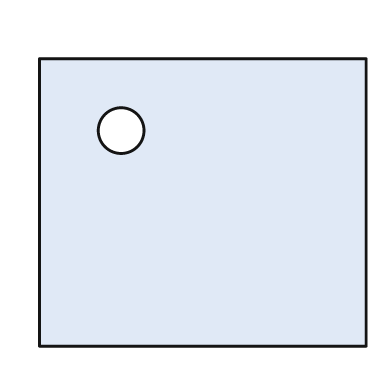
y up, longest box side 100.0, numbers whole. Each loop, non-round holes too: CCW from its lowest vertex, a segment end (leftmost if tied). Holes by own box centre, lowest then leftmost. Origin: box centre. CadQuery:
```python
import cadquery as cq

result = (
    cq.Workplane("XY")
    .moveTo(-50.0, -44.0)
    .lineTo(50.0, -44.0)
    .lineTo(50.0, 44.0)
    .lineTo(-50.0, 44.0)
    .close()
    .moveTo(-25.0, 22.0)
    .circle(7.0)
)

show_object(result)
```